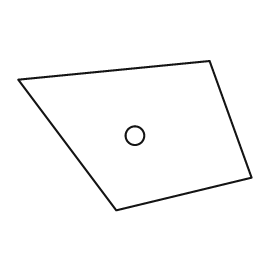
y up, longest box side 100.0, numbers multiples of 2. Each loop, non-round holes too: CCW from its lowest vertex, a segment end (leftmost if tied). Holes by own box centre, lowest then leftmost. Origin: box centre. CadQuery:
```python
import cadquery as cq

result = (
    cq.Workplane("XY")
    .moveTo(-8.0, -32.0)
    .lineTo(50.0, -18.0)
    .lineTo(32.0, 32.0)
    .lineTo(-50.0, 24.0)
    .close()
    .moveTo(0.0, 0.0)
    .circle(4.0)
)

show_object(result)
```